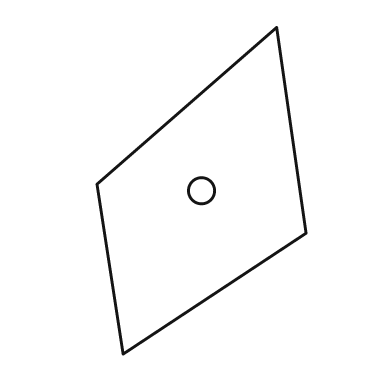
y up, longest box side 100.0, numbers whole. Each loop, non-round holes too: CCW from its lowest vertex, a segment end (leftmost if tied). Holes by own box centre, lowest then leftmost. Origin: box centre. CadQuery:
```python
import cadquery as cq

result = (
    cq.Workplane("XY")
    .moveTo(-24.0, -50.0)
    .lineTo(32.0, -13.0)
    .lineTo(23.0, 50.0)
    .lineTo(-32.0, 2.0)
    .close()
    .moveTo(0.0, 0.0)
    .circle(4.0)
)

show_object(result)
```